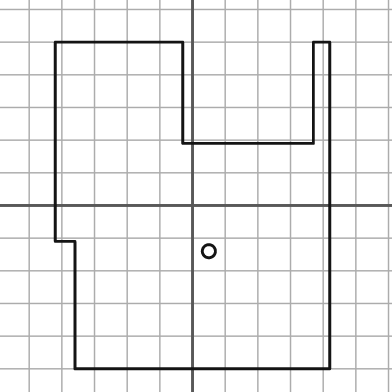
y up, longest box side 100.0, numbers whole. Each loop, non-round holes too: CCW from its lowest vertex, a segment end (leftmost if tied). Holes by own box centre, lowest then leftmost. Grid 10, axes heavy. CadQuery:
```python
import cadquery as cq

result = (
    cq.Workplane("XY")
    .moveTo(-36.0, -50.0)
    .lineTo(42.0, -50.0)
    .lineTo(42.0, 50.0)
    .lineTo(37.0, 50.0)
    .lineTo(37.0, 19.0)
    .lineTo(-3.0, 19.0)
    .lineTo(-3.0, 50.0)
    .lineTo(-42.0, 50.0)
    .lineTo(-42.0, -11.0)
    .lineTo(-36.0, -11.0)
    .close()
    .moveTo(5.0, -14.0)
    .circle(2.0)
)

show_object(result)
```